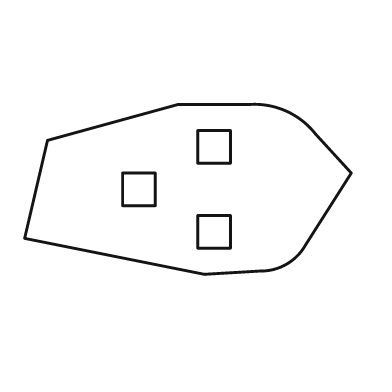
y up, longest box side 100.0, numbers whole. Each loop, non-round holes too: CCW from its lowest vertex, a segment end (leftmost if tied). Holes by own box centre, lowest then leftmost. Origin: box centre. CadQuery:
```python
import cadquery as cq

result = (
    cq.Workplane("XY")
    .moveTo(5.0, -26.0)
    .lineTo(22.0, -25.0)
    .threePointArc((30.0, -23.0), (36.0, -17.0))
    .lineTo(50.0, 5.0)
    .lineTo(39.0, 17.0)
    .threePointArc((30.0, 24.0), (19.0, 26.0))
    .lineTo(-3.0, 26.0)
    .lineTo(-43.0, 15.0)
    .lineTo(-50.0, -15.0)
    .close()
    .moveTo(3.0, -18.0)
    .lineTo(13.0, -18.0)
    .lineTo(13.0, -8.0)
    .lineTo(3.0, -8.0)
    .close()
    .moveTo(-20.0, -5.0)
    .lineTo(-10.0, -5.0)
    .lineTo(-10.0, 5.0)
    .lineTo(-20.0, 5.0)
    .close()
    .moveTo(3.0, 8.0)
    .lineTo(13.0, 8.0)
    .lineTo(13.0, 18.0)
    .lineTo(3.0, 18.0)
    .close()
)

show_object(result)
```